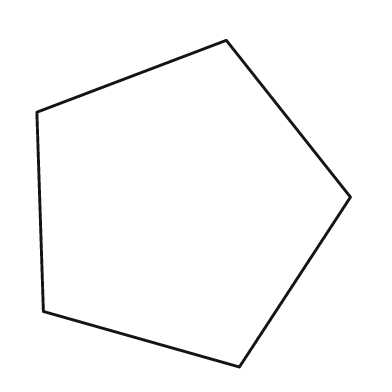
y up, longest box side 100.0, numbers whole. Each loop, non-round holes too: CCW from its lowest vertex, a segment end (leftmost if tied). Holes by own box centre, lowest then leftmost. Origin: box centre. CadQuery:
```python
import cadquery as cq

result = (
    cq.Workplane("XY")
    .moveTo(14.0, -50.0)
    .lineTo(48.0, 2.0)
    .lineTo(10.0, 50.0)
    .lineTo(-48.0, 28.0)
    .lineTo(-46.0, -33.0)
    .close()
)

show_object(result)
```